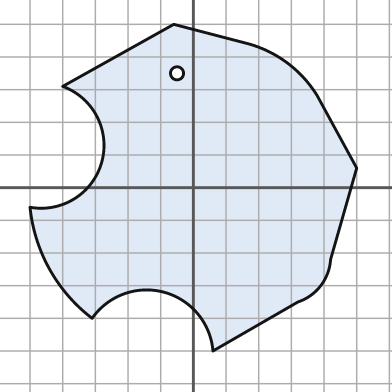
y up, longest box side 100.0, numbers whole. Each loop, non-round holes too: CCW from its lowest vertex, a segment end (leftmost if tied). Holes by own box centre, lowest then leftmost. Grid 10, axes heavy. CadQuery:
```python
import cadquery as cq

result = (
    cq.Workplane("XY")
    .moveTo(6.0, -50.0)
    .lineTo(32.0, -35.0)
    .threePointArc((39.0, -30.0), (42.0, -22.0))
    .lineTo(50.0, 6.0)
    .lineTo(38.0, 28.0)
    .threePointArc((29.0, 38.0), (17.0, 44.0))
    .lineTo(-6.0, 50.0)
    .lineTo(-40.0, 31.0)
    .threePointArc((-28.0, 8.0), (-50.0, -6.0))
    .threePointArc((-44.0, -25.0), (-31.0, -40.0))
    .threePointArc((-9.0, -32.0), (6.0, -50.0))
    .close()
    .moveTo(-5.0, 35.0)
    .circle(2.0)
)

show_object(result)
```